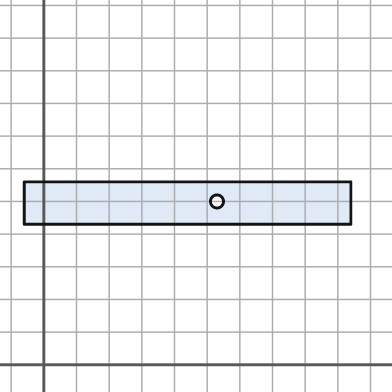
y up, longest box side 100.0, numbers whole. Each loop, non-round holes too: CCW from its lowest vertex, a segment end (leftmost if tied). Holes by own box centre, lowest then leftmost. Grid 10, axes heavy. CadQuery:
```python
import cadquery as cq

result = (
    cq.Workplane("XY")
    .moveTo(-6.0, 43.0)
    .lineTo(94.0, 43.0)
    .lineTo(94.0, 56.0)
    .lineTo(-6.0, 56.0)
    .close()
    .moveTo(53.0, 50.0)
    .circle(2.0)
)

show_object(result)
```